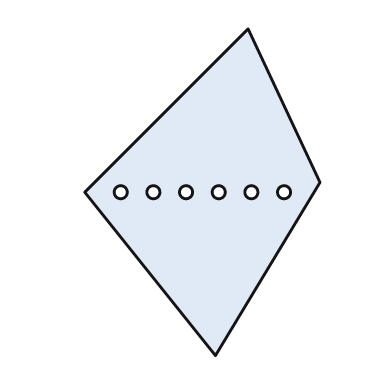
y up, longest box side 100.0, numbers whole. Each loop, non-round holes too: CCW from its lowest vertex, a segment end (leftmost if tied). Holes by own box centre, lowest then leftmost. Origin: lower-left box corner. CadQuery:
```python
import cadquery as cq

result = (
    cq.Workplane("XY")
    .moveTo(40.0, 0.0)
    .lineTo(72.0, 53.0)
    .lineTo(50.0, 100.0)
    .lineTo(0.0, 50.0)
    .close()
    .moveTo(11.0, 50.0)
    .circle(2.0)
    .moveTo(21.0, 50.0)
    .circle(2.0)
    .moveTo(31.0, 50.0)
    .circle(2.0)
    .moveTo(41.0, 50.0)
    .circle(2.0)
    .moveTo(51.0, 50.0)
    .circle(2.0)
    .moveTo(61.0, 50.0)
    .circle(2.0)
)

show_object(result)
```